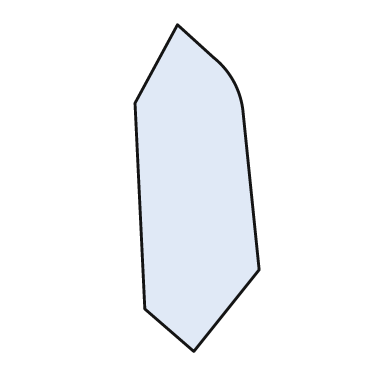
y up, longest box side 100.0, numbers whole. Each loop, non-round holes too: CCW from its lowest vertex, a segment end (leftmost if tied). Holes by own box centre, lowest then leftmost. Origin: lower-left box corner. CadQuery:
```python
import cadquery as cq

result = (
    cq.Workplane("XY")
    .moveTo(18.0, 0.0)
    .lineTo(38.0, 25.0)
    .lineTo(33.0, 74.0)
    .threePointArc((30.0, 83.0), (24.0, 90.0))
    .lineTo(13.0, 100.0)
    .lineTo(0.0, 76.0)
    .lineTo(3.0, 13.0)
    .close()
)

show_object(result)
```